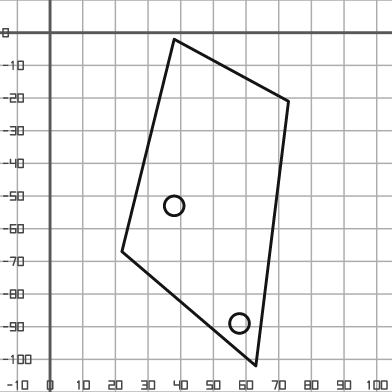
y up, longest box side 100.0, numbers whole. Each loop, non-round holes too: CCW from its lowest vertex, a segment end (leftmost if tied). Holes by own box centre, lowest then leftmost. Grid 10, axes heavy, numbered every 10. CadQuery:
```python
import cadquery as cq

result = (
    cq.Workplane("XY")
    .moveTo(63.0, -102.0)
    .lineTo(73.0, -21.0)
    .lineTo(38.0, -2.0)
    .lineTo(22.0, -67.0)
    .close()
    .moveTo(58.0, -89.0)
    .circle(3.0)
    .moveTo(38.0, -53.0)
    .circle(3.0)
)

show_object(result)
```